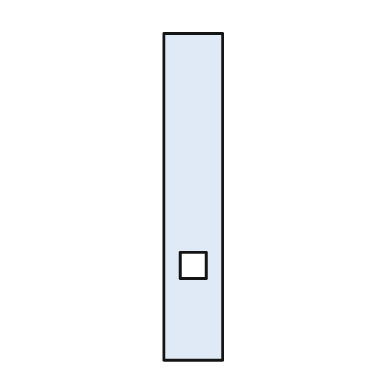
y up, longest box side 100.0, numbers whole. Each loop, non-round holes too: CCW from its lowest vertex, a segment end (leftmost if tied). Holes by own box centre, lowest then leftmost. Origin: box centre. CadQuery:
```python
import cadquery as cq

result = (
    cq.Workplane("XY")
    .moveTo(-9.0, -50.0)
    .lineTo(9.0, -50.0)
    .lineTo(9.0, 50.0)
    .lineTo(-9.0, 50.0)
    .close()
    .moveTo(-4.0, -25.0)
    .lineTo(4.0, -25.0)
    .lineTo(4.0, -17.0)
    .lineTo(-4.0, -17.0)
    .close()
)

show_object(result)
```